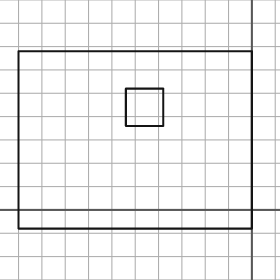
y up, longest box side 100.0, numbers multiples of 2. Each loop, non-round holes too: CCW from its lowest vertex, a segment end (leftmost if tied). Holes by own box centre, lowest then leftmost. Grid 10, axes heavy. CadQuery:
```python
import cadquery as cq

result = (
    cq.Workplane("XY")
    .moveTo(-100.0, -8.0)
    .lineTo(0.0, -8.0)
    .lineTo(0.0, 68.0)
    .lineTo(-100.0, 68.0)
    .close()
    .moveTo(-54.0, 36.0)
    .lineTo(-38.0, 36.0)
    .lineTo(-38.0, 52.0)
    .lineTo(-54.0, 52.0)
    .close()
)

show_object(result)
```